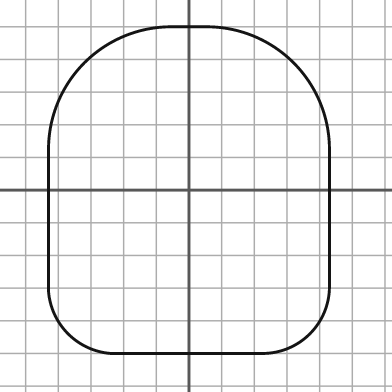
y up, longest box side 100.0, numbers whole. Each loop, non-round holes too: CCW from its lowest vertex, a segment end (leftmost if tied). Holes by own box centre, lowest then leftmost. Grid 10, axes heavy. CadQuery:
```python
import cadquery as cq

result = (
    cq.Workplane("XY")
    .moveTo(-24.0, -50.0)
    .lineTo(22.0, -50.0)
    .threePointArc((37.0, -44.0), (43.0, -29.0))
    .lineTo(43.0, 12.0)
    .threePointArc((32.0, 39.0), (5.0, 50.0))
    .lineTo(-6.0, 50.0)
    .threePointArc((-32.0, 39.0), (-43.0, 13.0))
    .lineTo(-43.0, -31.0)
    .threePointArc((-37.0, -44.0), (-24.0, -50.0))
    .close()
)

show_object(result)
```